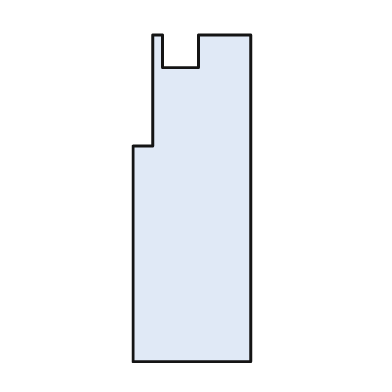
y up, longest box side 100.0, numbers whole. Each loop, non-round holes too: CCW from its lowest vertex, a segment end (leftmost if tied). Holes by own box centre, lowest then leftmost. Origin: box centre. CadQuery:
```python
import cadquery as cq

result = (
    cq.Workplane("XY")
    .moveTo(-18.0, -50.0)
    .lineTo(18.0, -50.0)
    .lineTo(18.0, 50.0)
    .lineTo(2.0, 50.0)
    .lineTo(2.0, 40.0)
    .lineTo(-9.0, 40.0)
    .lineTo(-9.0, 50.0)
    .lineTo(-12.0, 50.0)
    .lineTo(-12.0, 16.0)
    .lineTo(-18.0, 16.0)
    .close()
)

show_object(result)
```